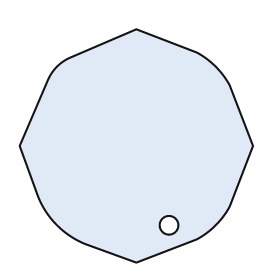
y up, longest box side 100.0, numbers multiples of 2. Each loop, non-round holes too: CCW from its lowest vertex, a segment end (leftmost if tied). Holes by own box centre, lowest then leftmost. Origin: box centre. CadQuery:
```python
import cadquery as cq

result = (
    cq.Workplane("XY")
    .moveTo(0.0, -50.0)
    .lineTo(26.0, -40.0)
    .threePointArc((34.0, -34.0), (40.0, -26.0))
    .lineTo(50.0, 0.0)
    .lineTo(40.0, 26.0)
    .threePointArc((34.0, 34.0), (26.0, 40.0))
    .lineTo(0.0, 50.0)
    .lineTo(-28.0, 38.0)
    .threePointArc((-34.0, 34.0), (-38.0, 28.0))
    .lineTo(-50.0, 0.0)
    .lineTo(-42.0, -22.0)
    .threePointArc((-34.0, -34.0), (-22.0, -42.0))
    .close()
    .moveTo(14.0, -34.0)
    .circle(4.0)
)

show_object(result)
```